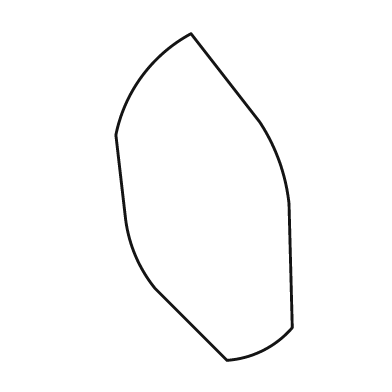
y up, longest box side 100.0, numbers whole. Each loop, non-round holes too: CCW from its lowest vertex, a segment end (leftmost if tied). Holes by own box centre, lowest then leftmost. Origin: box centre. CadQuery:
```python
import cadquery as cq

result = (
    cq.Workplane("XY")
    .moveTo(7.0, -50.0)
    .threePointArc((18.0, -47.0), (27.0, -40.0))
    .lineTo(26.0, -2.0)
    .threePointArc((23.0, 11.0), (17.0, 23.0))
    .lineTo(-4.0, 50.0)
    .threePointArc((-19.0, 37.0), (-27.0, 19.0))
    .lineTo(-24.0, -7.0)
    .threePointArc((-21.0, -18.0), (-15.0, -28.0))
    .close()
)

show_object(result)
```